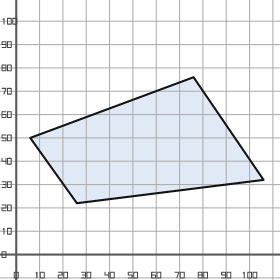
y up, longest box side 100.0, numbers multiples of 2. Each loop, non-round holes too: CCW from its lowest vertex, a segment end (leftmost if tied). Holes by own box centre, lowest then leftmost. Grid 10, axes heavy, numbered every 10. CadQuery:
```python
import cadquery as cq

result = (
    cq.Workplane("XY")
    .moveTo(26.0, 22.0)
    .lineTo(106.0, 32.0)
    .lineTo(76.0, 76.0)
    .lineTo(6.0, 50.0)
    .close()
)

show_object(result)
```